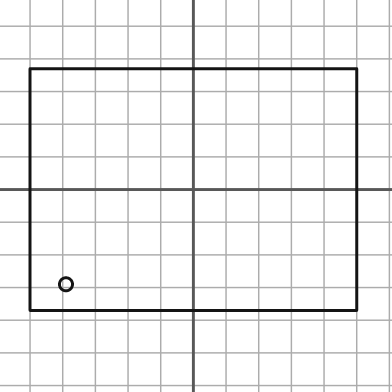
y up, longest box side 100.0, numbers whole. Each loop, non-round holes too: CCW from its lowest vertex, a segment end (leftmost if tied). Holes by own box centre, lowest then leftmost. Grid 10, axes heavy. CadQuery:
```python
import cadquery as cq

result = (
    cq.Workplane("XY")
    .moveTo(-50.0, -37.0)
    .lineTo(50.0, -37.0)
    .lineTo(50.0, 37.0)
    .lineTo(-50.0, 37.0)
    .close()
    .moveTo(-39.0, -29.0)
    .circle(2.0)
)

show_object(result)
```